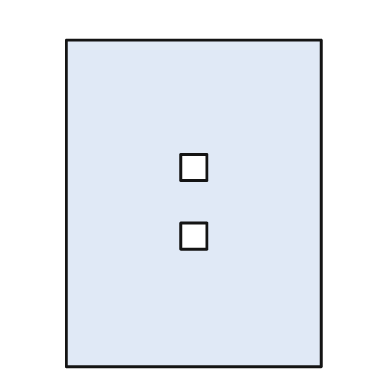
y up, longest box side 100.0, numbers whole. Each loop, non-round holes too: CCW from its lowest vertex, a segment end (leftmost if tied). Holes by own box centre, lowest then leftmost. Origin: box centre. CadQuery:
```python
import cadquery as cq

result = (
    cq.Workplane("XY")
    .moveTo(-39.0, -50.0)
    .lineTo(39.0, -50.0)
    .lineTo(39.0, 50.0)
    .lineTo(-39.0, 50.0)
    .close()
    .moveTo(-4.0, -14.0)
    .lineTo(4.0, -14.0)
    .lineTo(4.0, -6.0)
    .lineTo(-4.0, -6.0)
    .close()
    .moveTo(-4.0, 7.0)
    .lineTo(4.0, 7.0)
    .lineTo(4.0, 15.0)
    .lineTo(-4.0, 15.0)
    .close()
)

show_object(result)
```